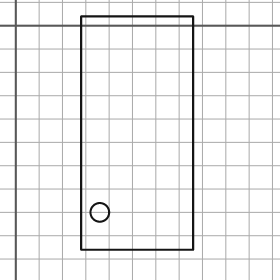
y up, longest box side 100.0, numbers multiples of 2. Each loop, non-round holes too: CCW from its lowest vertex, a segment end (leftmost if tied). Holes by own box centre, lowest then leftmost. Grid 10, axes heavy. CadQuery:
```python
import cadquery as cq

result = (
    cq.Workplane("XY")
    .moveTo(28.0, -96.0)
    .lineTo(76.0, -96.0)
    .lineTo(76.0, 4.0)
    .lineTo(28.0, 4.0)
    .close()
    .moveTo(36.0, -80.0)
    .circle(4.0)
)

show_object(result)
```